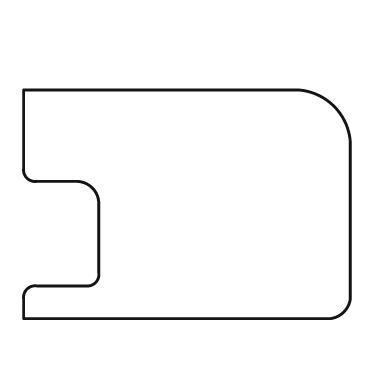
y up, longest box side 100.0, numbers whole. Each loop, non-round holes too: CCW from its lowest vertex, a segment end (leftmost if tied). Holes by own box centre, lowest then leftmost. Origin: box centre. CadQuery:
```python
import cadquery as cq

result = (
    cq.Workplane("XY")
    .moveTo(-50.0, -35.0)
    .lineTo(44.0, -35.0)
    .threePointArc((48.0, -33.0), (50.0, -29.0))
    .lineTo(50.0, 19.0)
    .threePointArc((45.0, 30.0), (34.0, 35.0))
    .lineTo(-50.0, 35.0)
    .lineTo(-50.0, 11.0)
    .threePointArc((-49.0, 8.0), (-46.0, 7.0))
    .lineTo(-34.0, 7.0)
    .threePointArc((-29.0, 5.0), (-27.0, 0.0))
    .lineTo(-27.0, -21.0)
    .threePointArc((-28.0, -24.0), (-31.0, -25.0))
    .lineTo(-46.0, -25.0)
    .threePointArc((-49.0, -26.0), (-50.0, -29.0))
    .close()
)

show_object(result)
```